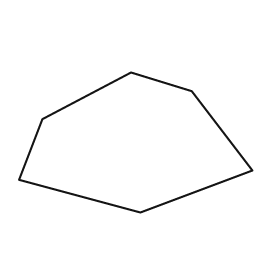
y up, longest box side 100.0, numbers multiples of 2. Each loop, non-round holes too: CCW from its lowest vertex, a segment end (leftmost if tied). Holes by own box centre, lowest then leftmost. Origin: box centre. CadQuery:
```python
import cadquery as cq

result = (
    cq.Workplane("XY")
    .moveTo(2.0, -30.0)
    .lineTo(50.0, -12.0)
    .lineTo(24.0, 22.0)
    .lineTo(-2.0, 30.0)
    .lineTo(-40.0, 10.0)
    .lineTo(-50.0, -16.0)
    .close()
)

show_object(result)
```